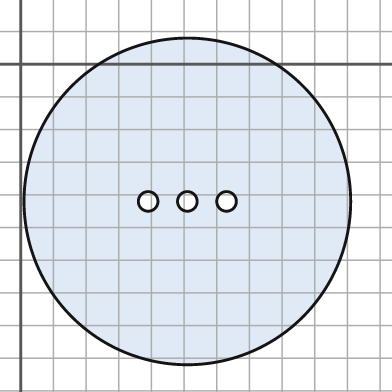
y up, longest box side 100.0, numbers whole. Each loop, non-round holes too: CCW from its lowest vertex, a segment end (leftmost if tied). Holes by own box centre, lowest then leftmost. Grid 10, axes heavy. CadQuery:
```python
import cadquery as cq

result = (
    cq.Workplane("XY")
    .moveTo(51.0, -42.0)
    .circle(50.0)
    .moveTo(39.0, -42.0)
    .circle(3.0)
    .moveTo(51.0, -42.0)
    .circle(3.0)
    .moveTo(63.0, -42.0)
    .circle(3.0)
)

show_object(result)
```